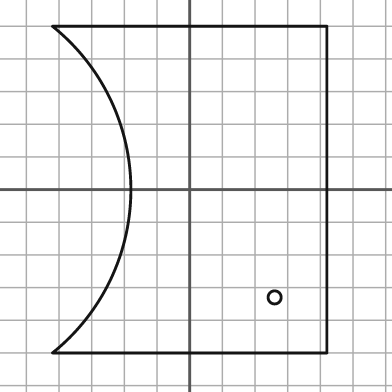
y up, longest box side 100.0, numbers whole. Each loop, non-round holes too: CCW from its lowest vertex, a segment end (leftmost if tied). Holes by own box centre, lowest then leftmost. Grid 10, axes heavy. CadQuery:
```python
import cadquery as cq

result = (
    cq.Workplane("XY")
    .moveTo(-42.0, -50.0)
    .lineTo(42.0, -50.0)
    .lineTo(42.0, 50.0)
    .lineTo(-42.0, 50.0)
    .threePointArc((-18.0, 0.0), (-42.0, -50.0))
    .close()
    .moveTo(26.0, -33.0)
    .circle(2.0)
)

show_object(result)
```